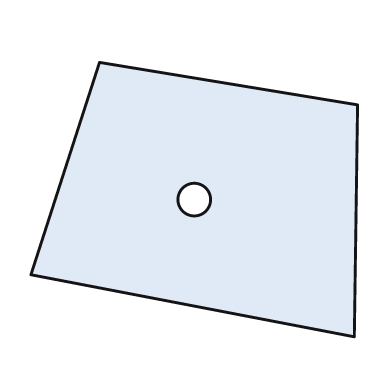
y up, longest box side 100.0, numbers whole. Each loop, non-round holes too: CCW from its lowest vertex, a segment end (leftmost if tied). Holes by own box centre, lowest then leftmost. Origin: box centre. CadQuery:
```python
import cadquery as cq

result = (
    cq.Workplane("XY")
    .moveTo(49.0, -42.0)
    .lineTo(50.0, 29.0)
    .lineTo(-29.0, 42.0)
    .lineTo(-50.0, -23.0)
    .close()
    .moveTo(0.0, 0.0)
    .circle(5.0)
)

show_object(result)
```